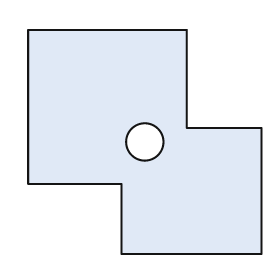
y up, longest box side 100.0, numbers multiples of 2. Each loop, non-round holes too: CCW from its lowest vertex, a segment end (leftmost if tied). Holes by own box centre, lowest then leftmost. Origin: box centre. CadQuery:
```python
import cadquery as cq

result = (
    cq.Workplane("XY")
    .moveTo(-10.0, -48.0)
    .lineTo(50.0, -48.0)
    .lineTo(50.0, 6.0)
    .lineTo(18.0, 6.0)
    .lineTo(18.0, 48.0)
    .lineTo(-50.0, 48.0)
    .lineTo(-50.0, -18.0)
    .lineTo(-10.0, -18.0)
    .close()
    .moveTo(0.0, 0.0)
    .circle(8.0)
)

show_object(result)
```